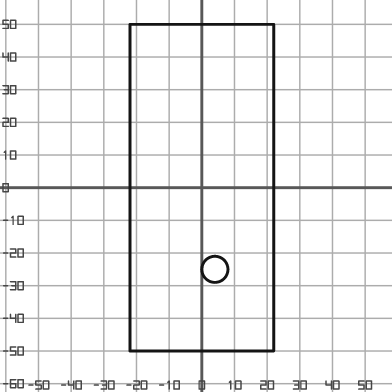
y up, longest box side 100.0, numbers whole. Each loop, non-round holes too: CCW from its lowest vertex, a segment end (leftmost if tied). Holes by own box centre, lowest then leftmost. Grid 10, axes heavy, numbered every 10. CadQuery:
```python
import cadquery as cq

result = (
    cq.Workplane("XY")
    .moveTo(-22.0, -50.0)
    .lineTo(22.0, -50.0)
    .lineTo(22.0, 50.0)
    .lineTo(-22.0, 50.0)
    .close()
    .moveTo(4.0, -25.0)
    .circle(4.0)
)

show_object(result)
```